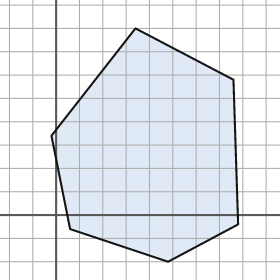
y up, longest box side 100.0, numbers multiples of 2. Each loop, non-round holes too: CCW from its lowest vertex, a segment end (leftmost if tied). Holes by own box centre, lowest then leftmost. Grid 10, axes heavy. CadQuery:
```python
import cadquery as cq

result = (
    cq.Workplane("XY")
    .moveTo(48.0, -20.0)
    .lineTo(78.0, -4.0)
    .lineTo(76.0, 58.0)
    .lineTo(34.0, 80.0)
    .lineTo(-2.0, 34.0)
    .lineTo(6.0, -6.0)
    .close()
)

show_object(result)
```